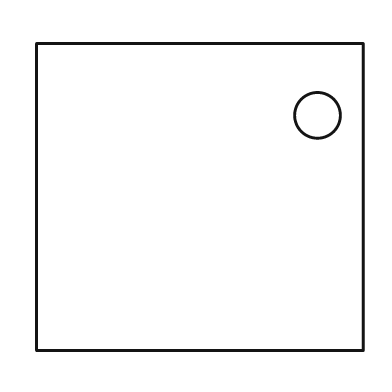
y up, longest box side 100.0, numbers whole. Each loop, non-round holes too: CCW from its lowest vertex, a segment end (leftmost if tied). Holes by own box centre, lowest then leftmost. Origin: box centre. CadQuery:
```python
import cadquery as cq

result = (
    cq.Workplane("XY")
    .moveTo(-50.0, -47.0)
    .lineTo(50.0, -47.0)
    .lineTo(50.0, 47.0)
    .lineTo(-50.0, 47.0)
    .close()
    .moveTo(36.0, 25.0)
    .circle(7.0)
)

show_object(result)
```